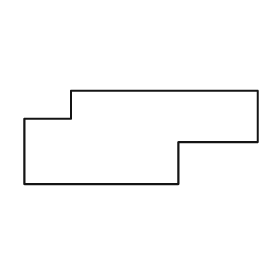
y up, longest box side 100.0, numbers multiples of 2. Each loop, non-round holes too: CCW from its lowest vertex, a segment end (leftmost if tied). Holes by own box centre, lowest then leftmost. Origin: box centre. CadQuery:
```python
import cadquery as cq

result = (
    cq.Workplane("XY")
    .moveTo(-50.0, -20.0)
    .lineTo(16.0, -20.0)
    .lineTo(16.0, -2.0)
    .lineTo(50.0, -2.0)
    .lineTo(50.0, 20.0)
    .lineTo(-30.0, 20.0)
    .lineTo(-30.0, 8.0)
    .lineTo(-50.0, 8.0)
    .close()
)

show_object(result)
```